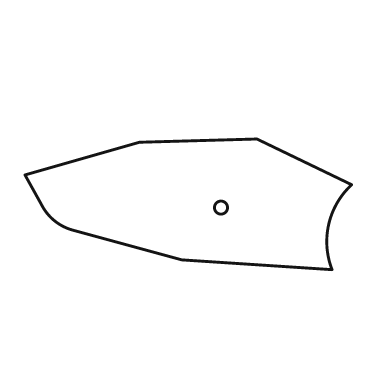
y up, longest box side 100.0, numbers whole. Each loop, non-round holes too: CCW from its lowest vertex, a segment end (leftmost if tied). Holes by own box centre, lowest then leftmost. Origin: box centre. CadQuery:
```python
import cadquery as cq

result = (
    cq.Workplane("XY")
    .moveTo(44.0, -20.0)
    .threePointArc((43.0, -6.0), (50.0, 6.0))
    .lineTo(21.0, 20.0)
    .lineTo(-15.0, 19.0)
    .lineTo(-50.0, 9.0)
    .lineTo(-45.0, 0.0)
    .threePointArc((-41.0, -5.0), (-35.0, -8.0))
    .lineTo(-2.0, -17.0)
    .close()
    .moveTo(10.0, -1.0)
    .circle(2.0)
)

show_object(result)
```